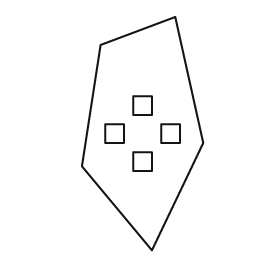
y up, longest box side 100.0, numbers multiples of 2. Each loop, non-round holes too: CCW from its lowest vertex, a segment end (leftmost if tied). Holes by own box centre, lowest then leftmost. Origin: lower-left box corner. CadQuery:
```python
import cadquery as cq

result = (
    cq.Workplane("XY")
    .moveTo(30.0, 0.0)
    .lineTo(52.0, 46.0)
    .lineTo(40.0, 100.0)
    .lineTo(8.0, 88.0)
    .lineTo(0.0, 36.0)
    .close()
    .moveTo(22.0, 34.0)
    .lineTo(30.0, 34.0)
    .lineTo(30.0, 42.0)
    .lineTo(22.0, 42.0)
    .close()
    .moveTo(10.0, 46.0)
    .lineTo(18.0, 46.0)
    .lineTo(18.0, 54.0)
    .lineTo(10.0, 54.0)
    .close()
    .moveTo(34.0, 46.0)
    .lineTo(42.0, 46.0)
    .lineTo(42.0, 54.0)
    .lineTo(34.0, 54.0)
    .close()
    .moveTo(22.0, 58.0)
    .lineTo(30.0, 58.0)
    .lineTo(30.0, 66.0)
    .lineTo(22.0, 66.0)
    .close()
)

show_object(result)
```